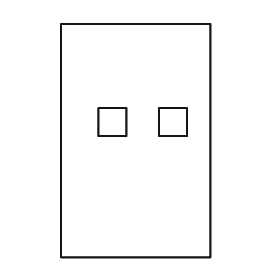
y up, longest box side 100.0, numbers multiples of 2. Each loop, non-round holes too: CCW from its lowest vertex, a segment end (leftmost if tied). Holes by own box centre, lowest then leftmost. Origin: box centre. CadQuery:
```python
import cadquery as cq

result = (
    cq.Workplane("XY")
    .moveTo(-32.0, -50.0)
    .lineTo(32.0, -50.0)
    .lineTo(32.0, 50.0)
    .lineTo(-32.0, 50.0)
    .close()
    .moveTo(-16.0, 2.0)
    .lineTo(-4.0, 2.0)
    .lineTo(-4.0, 14.0)
    .lineTo(-16.0, 14.0)
    .close()
    .moveTo(10.0, 2.0)
    .lineTo(22.0, 2.0)
    .lineTo(22.0, 14.0)
    .lineTo(10.0, 14.0)
    .close()
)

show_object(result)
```